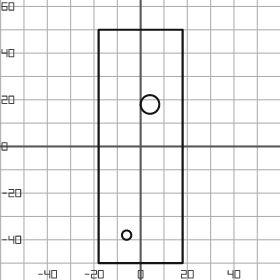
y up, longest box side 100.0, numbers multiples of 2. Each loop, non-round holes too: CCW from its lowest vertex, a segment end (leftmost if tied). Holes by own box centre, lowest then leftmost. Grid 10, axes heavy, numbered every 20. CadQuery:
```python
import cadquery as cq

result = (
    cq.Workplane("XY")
    .moveTo(-18.0, -50.0)
    .lineTo(18.0, -50.0)
    .lineTo(18.0, 50.0)
    .lineTo(-18.0, 50.0)
    .close()
    .moveTo(-6.0, -38.0)
    .circle(2.0)
    .moveTo(4.0, 18.0)
    .circle(4.0)
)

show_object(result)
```